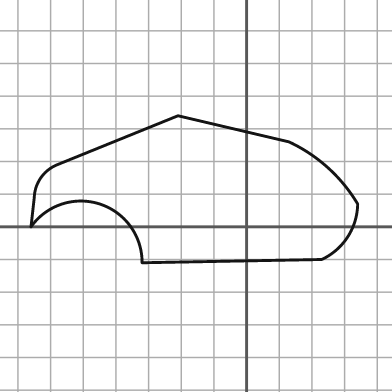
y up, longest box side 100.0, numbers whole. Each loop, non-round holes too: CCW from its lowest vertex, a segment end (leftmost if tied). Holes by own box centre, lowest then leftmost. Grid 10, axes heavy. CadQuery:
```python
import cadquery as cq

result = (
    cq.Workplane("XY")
    .moveTo(-32.0, -11.0)
    .lineTo(23.0, -10.0)
    .threePointArc((31.0, -3.0), (34.0, 7.0))
    .threePointArc((25.0, 18.0), (13.0, 26.0))
    .lineTo(-21.0, 34.0)
    .lineTo(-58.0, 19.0)
    .threePointArc((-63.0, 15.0), (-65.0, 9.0))
    .lineTo(-66.0, 0.0)
    .threePointArc((-45.0, 7.0), (-32.0, -11.0))
    .close()
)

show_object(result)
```